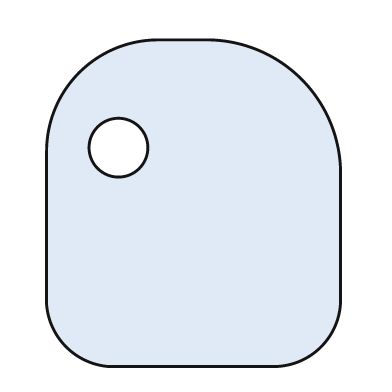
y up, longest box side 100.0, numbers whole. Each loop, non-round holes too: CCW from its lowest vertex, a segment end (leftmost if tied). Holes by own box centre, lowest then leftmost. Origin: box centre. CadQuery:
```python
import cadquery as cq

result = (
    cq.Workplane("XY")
    .moveTo(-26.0, -50.0)
    .lineTo(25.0, -50.0)
    .threePointArc((39.0, -44.0), (45.0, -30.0))
    .lineTo(45.0, 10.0)
    .threePointArc((33.0, 38.0), (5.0, 50.0))
    .lineTo(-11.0, 50.0)
    .threePointArc((-35.0, 40.0), (-45.0, 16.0))
    .lineTo(-45.0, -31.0)
    .threePointArc((-39.0, -44.0), (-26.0, -50.0))
    .close()
    .moveTo(-23.0, 17.0)
    .circle(9.0)
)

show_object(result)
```